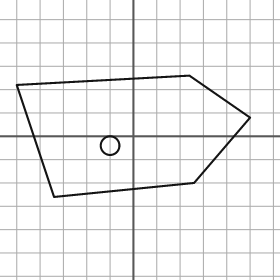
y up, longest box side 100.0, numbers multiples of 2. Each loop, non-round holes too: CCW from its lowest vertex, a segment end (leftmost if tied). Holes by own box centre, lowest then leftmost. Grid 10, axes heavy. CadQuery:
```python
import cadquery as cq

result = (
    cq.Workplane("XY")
    .moveTo(-34.0, -26.0)
    .lineTo(26.0, -20.0)
    .lineTo(50.0, 8.0)
    .lineTo(24.0, 26.0)
    .lineTo(-50.0, 22.0)
    .close()
    .moveTo(-10.0, -4.0)
    .circle(4.0)
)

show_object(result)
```